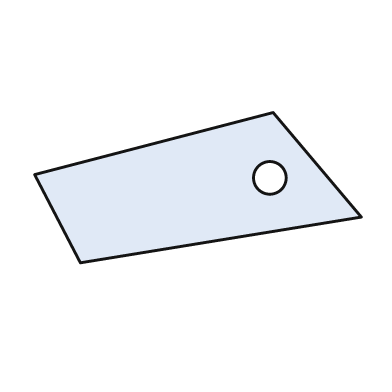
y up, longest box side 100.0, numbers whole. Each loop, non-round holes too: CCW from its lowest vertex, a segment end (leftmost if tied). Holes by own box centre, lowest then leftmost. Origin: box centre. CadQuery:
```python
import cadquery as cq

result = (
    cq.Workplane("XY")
    .moveTo(-36.0, -23.0)
    .lineTo(50.0, -9.0)
    .lineTo(23.0, 23.0)
    .lineTo(-50.0, 4.0)
    .close()
    .moveTo(22.0, 3.0)
    .circle(5.0)
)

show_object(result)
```